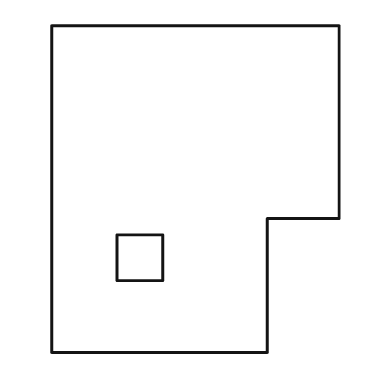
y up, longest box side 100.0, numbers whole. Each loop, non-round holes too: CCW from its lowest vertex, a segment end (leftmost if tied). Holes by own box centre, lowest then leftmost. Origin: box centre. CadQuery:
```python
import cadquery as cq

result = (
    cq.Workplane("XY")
    .moveTo(-44.0, -50.0)
    .lineTo(22.0, -50.0)
    .lineTo(22.0, -9.0)
    .lineTo(44.0, -9.0)
    .lineTo(44.0, 50.0)
    .lineTo(-44.0, 50.0)
    .close()
    .moveTo(-24.0, -28.0)
    .lineTo(-10.0, -28.0)
    .lineTo(-10.0, -14.0)
    .lineTo(-24.0, -14.0)
    .close()
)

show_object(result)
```